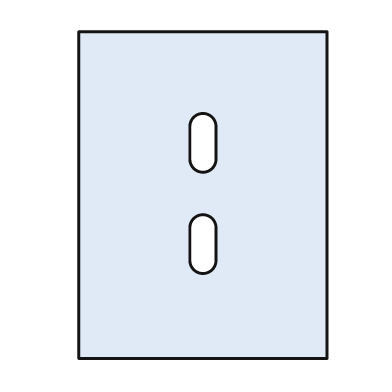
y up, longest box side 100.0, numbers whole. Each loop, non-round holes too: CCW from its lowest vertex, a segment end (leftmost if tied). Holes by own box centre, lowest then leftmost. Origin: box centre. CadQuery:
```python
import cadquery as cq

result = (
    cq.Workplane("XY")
    .moveTo(-38.0, -50.0)
    .lineTo(38.0, -50.0)
    .lineTo(38.0, 50.0)
    .lineTo(-38.0, 50.0)
    .close()
    .moveTo(-4.0, -20.0)
    .threePointArc((0.0, -24.0), (4.0, -20.0))
    .lineTo(4.0, -10.0)
    .threePointArc((0.0, -6.0), (-4.0, -10.0))
    .close()
    .moveTo(-4.0, 11.0)
    .threePointArc((0.0, 7.0), (4.0, 11.0))
    .lineTo(4.0, 21.0)
    .threePointArc((0.0, 25.0), (-4.0, 21.0))
    .close()
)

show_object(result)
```